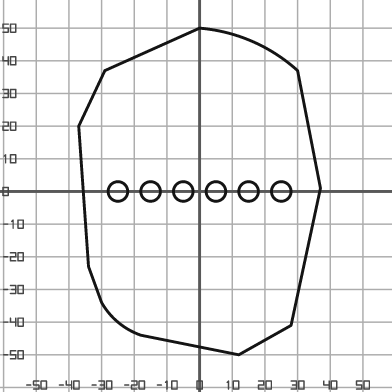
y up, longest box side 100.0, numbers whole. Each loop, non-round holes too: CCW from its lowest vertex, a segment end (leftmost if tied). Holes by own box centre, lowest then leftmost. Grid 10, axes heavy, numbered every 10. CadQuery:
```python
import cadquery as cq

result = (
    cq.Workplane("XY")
    .moveTo(12.0, -50.0)
    .lineTo(28.0, -41.0)
    .lineTo(37.0, 1.0)
    .lineTo(30.0, 37.0)
    .threePointArc((16.0, 46.0), (0.0, 50.0))
    .lineTo(-29.0, 37.0)
    .lineTo(-37.0, 20.0)
    .lineTo(-34.0, -23.0)
    .lineTo(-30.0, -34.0)
    .threePointArc((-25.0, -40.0), (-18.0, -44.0))
    .close()
    .moveTo(-25.0, 0.0)
    .circle(3.0)
    .moveTo(-15.0, 0.0)
    .circle(3.0)
    .moveTo(-5.0, 0.0)
    .circle(3.0)
    .moveTo(5.0, 0.0)
    .circle(3.0)
    .moveTo(15.0, 0.0)
    .circle(3.0)
    .moveTo(25.0, 0.0)
    .circle(3.0)
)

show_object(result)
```